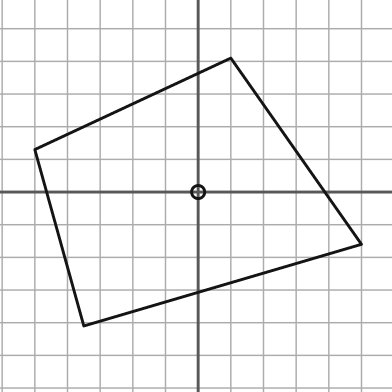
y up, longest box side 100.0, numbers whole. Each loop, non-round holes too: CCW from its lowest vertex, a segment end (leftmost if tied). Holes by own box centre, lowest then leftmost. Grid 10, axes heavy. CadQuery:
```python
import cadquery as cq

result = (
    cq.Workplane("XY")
    .moveTo(-35.0, -41.0)
    .lineTo(50.0, -16.0)
    .lineTo(10.0, 41.0)
    .lineTo(-50.0, 13.0)
    .close()
    .moveTo(0.0, 0.0)
    .circle(2.0)
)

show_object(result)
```